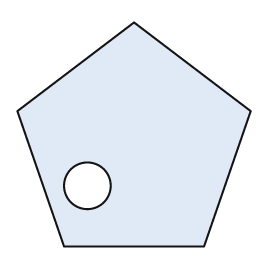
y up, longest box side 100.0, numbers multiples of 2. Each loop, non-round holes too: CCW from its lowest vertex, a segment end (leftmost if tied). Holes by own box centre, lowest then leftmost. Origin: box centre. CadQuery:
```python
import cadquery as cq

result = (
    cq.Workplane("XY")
    .moveTo(-30.0, -48.0)
    .lineTo(30.0, -48.0)
    .lineTo(50.0, 10.0)
    .lineTo(0.0, 48.0)
    .lineTo(-50.0, 10.0)
    .close()
    .moveTo(-20.0, -22.0)
    .circle(10.0)
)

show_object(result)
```